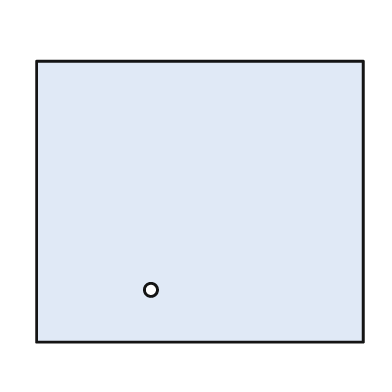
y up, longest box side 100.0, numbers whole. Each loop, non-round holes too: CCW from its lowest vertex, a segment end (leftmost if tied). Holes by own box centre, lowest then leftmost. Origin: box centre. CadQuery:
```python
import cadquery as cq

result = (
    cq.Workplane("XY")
    .moveTo(-50.0, -43.0)
    .lineTo(50.0, -43.0)
    .lineTo(50.0, 43.0)
    .lineTo(-50.0, 43.0)
    .close()
    .moveTo(-15.0, -27.0)
    .circle(2.0)
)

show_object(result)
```